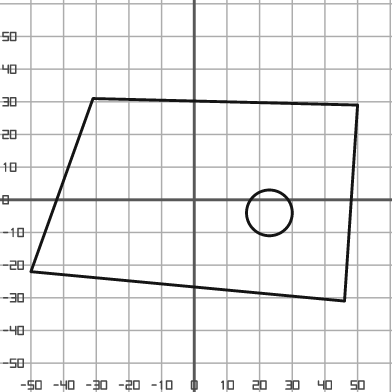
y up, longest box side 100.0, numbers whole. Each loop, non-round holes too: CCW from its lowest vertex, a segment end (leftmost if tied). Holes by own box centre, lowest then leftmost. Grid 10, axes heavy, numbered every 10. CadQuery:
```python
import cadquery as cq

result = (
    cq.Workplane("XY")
    .moveTo(46.0, -31.0)
    .lineTo(50.0, 29.0)
    .lineTo(-31.0, 31.0)
    .lineTo(-50.0, -22.0)
    .close()
    .moveTo(23.0, -4.0)
    .circle(7.0)
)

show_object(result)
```